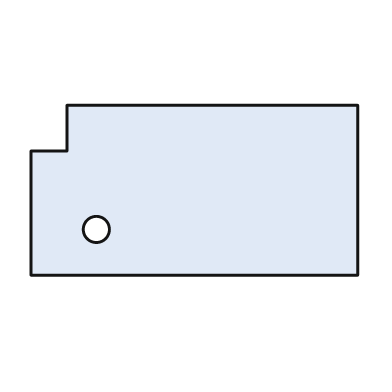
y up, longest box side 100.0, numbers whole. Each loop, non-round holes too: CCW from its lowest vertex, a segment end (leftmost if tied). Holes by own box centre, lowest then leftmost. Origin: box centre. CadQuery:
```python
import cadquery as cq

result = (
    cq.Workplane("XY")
    .moveTo(-50.0, -26.0)
    .lineTo(50.0, -26.0)
    .lineTo(50.0, 26.0)
    .lineTo(-39.0, 26.0)
    .lineTo(-39.0, 12.0)
    .lineTo(-50.0, 12.0)
    .close()
    .moveTo(-30.0, -12.0)
    .circle(4.0)
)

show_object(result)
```